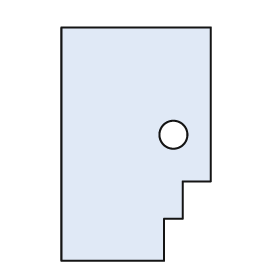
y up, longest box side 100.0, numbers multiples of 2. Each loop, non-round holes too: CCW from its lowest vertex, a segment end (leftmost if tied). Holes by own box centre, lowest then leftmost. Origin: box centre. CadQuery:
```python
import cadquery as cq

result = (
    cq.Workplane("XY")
    .moveTo(-32.0, -50.0)
    .lineTo(12.0, -50.0)
    .lineTo(12.0, -32.0)
    .lineTo(20.0, -32.0)
    .lineTo(20.0, -16.0)
    .lineTo(32.0, -16.0)
    .lineTo(32.0, 50.0)
    .lineTo(-32.0, 50.0)
    .close()
    .moveTo(16.0, 4.0)
    .circle(6.0)
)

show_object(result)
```